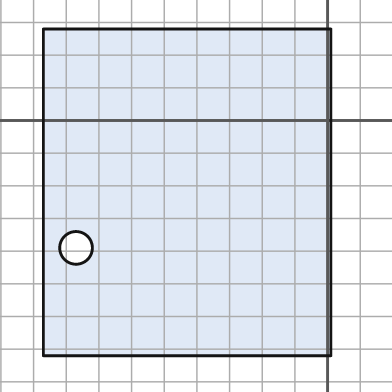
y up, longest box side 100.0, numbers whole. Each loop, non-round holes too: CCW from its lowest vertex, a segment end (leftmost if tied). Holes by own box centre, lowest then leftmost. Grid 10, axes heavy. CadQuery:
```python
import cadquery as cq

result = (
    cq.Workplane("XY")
    .moveTo(-87.0, -72.0)
    .lineTo(1.0, -72.0)
    .lineTo(1.0, 28.0)
    .lineTo(-87.0, 28.0)
    .close()
    .moveTo(-77.0, -39.0)
    .circle(5.0)
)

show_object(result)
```